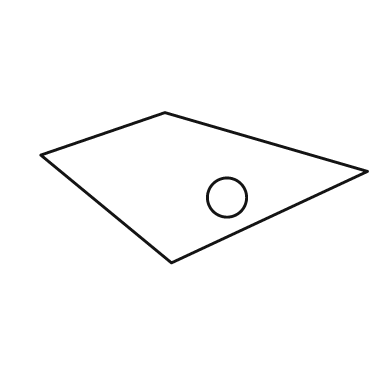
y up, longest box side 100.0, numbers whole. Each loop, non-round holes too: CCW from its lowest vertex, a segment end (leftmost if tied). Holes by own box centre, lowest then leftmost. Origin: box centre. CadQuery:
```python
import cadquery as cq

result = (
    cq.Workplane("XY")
    .moveTo(-10.0, -23.0)
    .lineTo(50.0, 5.0)
    .lineTo(-12.0, 23.0)
    .lineTo(-50.0, 10.0)
    .close()
    .moveTo(7.0, -3.0)
    .circle(6.0)
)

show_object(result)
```